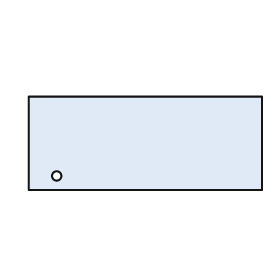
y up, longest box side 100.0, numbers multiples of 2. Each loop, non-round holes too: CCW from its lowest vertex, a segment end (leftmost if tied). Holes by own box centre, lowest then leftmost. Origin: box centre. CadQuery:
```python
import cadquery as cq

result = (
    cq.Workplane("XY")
    .moveTo(-50.0, -20.0)
    .lineTo(50.0, -20.0)
    .lineTo(50.0, 20.0)
    .lineTo(-50.0, 20.0)
    .close()
    .moveTo(-38.0, -14.0)
    .circle(2.0)
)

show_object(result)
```